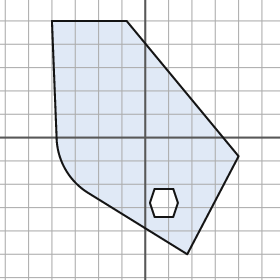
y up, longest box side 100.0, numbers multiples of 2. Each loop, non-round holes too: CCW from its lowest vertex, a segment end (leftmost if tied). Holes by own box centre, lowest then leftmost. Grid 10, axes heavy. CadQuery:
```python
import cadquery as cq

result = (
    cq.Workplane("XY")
    .moveTo(18.0, -50.0)
    .lineTo(40.0, -8.0)
    .lineTo(-8.0, 50.0)
    .lineTo(-40.0, 50.0)
    .lineTo(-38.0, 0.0)
    .threePointArc((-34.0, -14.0), (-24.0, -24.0))
    .close()
    .moveTo(4.0, -34.0)
    .lineTo(12.0, -34.0)
    .lineTo(14.0, -28.0)
    .lineTo(12.0, -22.0)
    .lineTo(4.0, -22.0)
    .lineTo(2.0, -28.0)
    .close()
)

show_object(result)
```